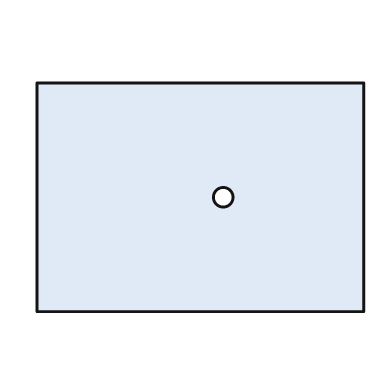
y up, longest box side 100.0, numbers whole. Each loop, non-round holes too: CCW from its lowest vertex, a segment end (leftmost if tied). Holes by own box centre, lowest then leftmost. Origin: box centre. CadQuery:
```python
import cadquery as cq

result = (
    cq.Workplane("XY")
    .moveTo(-50.0, -35.0)
    .lineTo(50.0, -35.0)
    .lineTo(50.0, 35.0)
    .lineTo(-50.0, 35.0)
    .close()
    .moveTo(7.0, 0.0)
    .circle(3.0)
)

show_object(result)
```